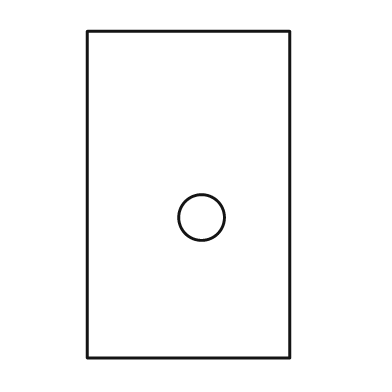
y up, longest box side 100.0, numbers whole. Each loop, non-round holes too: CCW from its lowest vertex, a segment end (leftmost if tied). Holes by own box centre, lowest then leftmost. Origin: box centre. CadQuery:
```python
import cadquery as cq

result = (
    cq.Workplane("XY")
    .moveTo(-31.0, -50.0)
    .lineTo(31.0, -50.0)
    .lineTo(31.0, 50.0)
    .lineTo(-31.0, 50.0)
    .close()
    .moveTo(4.0, -7.0)
    .circle(7.0)
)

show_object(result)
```